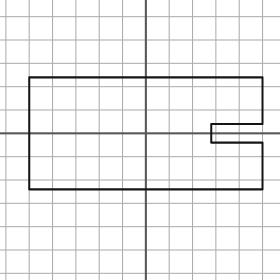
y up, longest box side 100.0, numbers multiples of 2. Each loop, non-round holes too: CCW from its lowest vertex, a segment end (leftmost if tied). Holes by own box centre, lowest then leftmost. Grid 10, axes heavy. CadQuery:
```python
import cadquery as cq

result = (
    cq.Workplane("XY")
    .moveTo(-50.0, -24.0)
    .lineTo(50.0, -24.0)
    .lineTo(50.0, -4.0)
    .lineTo(28.0, -4.0)
    .lineTo(28.0, 4.0)
    .lineTo(50.0, 4.0)
    .lineTo(50.0, 24.0)
    .lineTo(-50.0, 24.0)
    .close()
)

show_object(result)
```